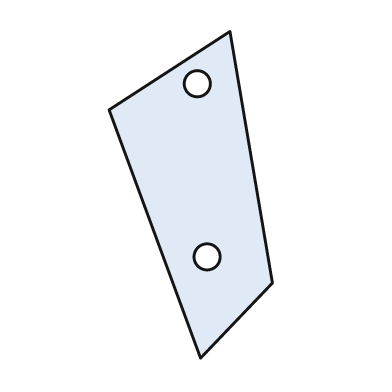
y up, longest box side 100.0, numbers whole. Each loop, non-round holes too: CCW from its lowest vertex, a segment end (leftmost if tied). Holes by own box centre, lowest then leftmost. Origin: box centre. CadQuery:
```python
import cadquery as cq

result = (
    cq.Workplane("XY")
    .moveTo(3.0, -50.0)
    .lineTo(25.0, -27.0)
    .lineTo(12.0, 50.0)
    .lineTo(-25.0, 26.0)
    .close()
    .moveTo(5.0, -19.0)
    .circle(4.0)
    .moveTo(2.0, 34.0)
    .circle(4.0)
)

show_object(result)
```